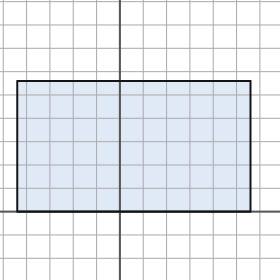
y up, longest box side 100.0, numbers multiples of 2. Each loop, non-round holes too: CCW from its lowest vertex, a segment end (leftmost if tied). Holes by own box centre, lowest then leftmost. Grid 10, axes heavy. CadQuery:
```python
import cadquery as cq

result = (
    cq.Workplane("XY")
    .moveTo(-44.0, 0.0)
    .lineTo(56.0, 0.0)
    .lineTo(56.0, 56.0)
    .lineTo(-44.0, 56.0)
    .close()
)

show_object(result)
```